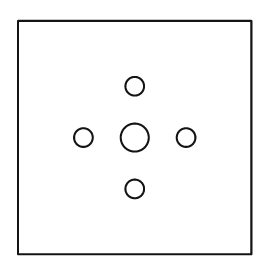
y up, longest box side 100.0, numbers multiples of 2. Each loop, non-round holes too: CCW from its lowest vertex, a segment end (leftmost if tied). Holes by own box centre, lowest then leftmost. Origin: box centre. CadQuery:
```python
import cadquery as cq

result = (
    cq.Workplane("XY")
    .moveTo(-50.0, -50.0)
    .lineTo(50.0, -50.0)
    .lineTo(50.0, 50.0)
    .lineTo(-50.0, 50.0)
    .close()
    .moveTo(0.0, -22.0)
    .circle(4.0)
    .moveTo(-22.0, 0.0)
    .circle(4.0)
    .moveTo(0.0, 0.0)
    .circle(6.0)
    .moveTo(22.0, 0.0)
    .circle(4.0)
    .moveTo(0.0, 22.0)
    .circle(4.0)
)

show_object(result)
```